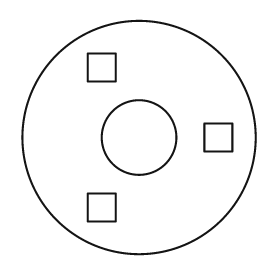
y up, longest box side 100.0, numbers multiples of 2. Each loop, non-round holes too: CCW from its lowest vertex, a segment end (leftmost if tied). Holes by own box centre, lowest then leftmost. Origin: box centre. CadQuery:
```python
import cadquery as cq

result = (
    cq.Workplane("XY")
    .moveTo(0.0, 0.0)
    .circle(50.0)
    .moveTo(-22.0, -36.0)
    .lineTo(-10.0, -36.0)
    .lineTo(-10.0, -24.0)
    .lineTo(-22.0, -24.0)
    .close()
    .moveTo(0.0, 0.0)
    .circle(16.0)
    .moveTo(28.0, -6.0)
    .lineTo(40.0, -6.0)
    .lineTo(40.0, 6.0)
    .lineTo(28.0, 6.0)
    .close()
    .moveTo(-22.0, 24.0)
    .lineTo(-10.0, 24.0)
    .lineTo(-10.0, 36.0)
    .lineTo(-22.0, 36.0)
    .close()
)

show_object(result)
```